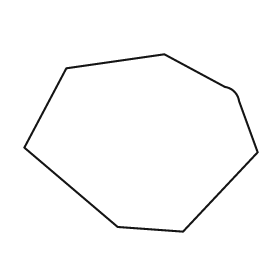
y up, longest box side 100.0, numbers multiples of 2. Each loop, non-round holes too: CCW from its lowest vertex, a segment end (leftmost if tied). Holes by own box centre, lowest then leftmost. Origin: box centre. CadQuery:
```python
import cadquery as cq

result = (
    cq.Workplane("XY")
    .moveTo(18.0, -38.0)
    .lineTo(50.0, -4.0)
    .lineTo(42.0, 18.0)
    .threePointArc((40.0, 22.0), (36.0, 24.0))
    .lineTo(10.0, 38.0)
    .lineTo(-32.0, 32.0)
    .lineTo(-50.0, -2.0)
    .lineTo(-10.0, -36.0)
    .close()
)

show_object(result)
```